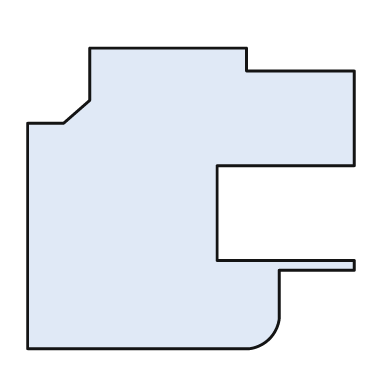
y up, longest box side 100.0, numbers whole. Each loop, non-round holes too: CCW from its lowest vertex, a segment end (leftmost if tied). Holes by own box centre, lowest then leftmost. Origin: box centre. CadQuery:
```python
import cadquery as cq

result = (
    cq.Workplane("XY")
    .moveTo(-50.0, -46.0)
    .lineTo(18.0, -46.0)
    .threePointArc((24.0, -43.0), (27.0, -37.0))
    .lineTo(27.0, -22.0)
    .lineTo(50.0, -22.0)
    .lineTo(50.0, -19.0)
    .lineTo(8.0, -19.0)
    .lineTo(8.0, 10.0)
    .lineTo(50.0, 10.0)
    .lineTo(50.0, 39.0)
    .lineTo(17.0, 39.0)
    .lineTo(17.0, 46.0)
    .lineTo(-31.0, 46.0)
    .lineTo(-31.0, 30.0)
    .lineTo(-39.0, 23.0)
    .lineTo(-50.0, 23.0)
    .close()
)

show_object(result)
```